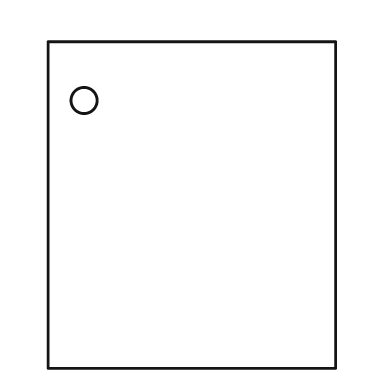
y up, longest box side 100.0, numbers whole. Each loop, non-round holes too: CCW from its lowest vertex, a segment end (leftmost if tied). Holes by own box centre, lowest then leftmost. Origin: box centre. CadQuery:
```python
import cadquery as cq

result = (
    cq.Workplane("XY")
    .moveTo(-44.0, -50.0)
    .lineTo(44.0, -50.0)
    .lineTo(44.0, 50.0)
    .lineTo(-44.0, 50.0)
    .close()
    .moveTo(-33.0, 32.0)
    .circle(4.0)
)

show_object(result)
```